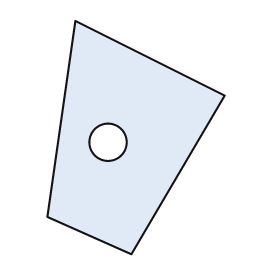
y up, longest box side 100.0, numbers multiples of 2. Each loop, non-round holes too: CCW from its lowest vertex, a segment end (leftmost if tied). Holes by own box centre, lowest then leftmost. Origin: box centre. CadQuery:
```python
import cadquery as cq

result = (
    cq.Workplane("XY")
    .moveTo(-2.0, -50.0)
    .lineTo(38.0, 18.0)
    .lineTo(-26.0, 50.0)
    .lineTo(-38.0, -34.0)
    .close()
    .moveTo(-12.0, -2.0)
    .circle(8.0)
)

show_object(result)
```